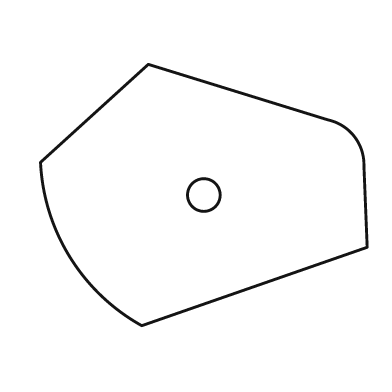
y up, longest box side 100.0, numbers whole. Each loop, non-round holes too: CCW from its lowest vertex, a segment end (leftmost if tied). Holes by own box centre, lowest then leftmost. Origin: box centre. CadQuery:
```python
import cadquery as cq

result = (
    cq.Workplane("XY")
    .moveTo(-19.0, -40.0)
    .lineTo(50.0, -16.0)
    .lineTo(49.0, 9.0)
    .threePointArc((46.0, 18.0), (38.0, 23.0))
    .lineTo(-17.0, 40.0)
    .lineTo(-50.0, 10.0)
    .threePointArc((-41.0, -19.0), (-19.0, -40.0))
    .close()
    .moveTo(0.0, 0.0)
    .circle(5.0)
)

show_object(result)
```